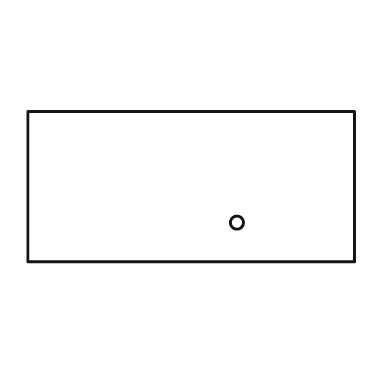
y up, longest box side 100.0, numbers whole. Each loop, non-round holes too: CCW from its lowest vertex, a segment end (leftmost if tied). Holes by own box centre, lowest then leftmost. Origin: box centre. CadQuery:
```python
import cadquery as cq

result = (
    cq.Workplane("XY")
    .moveTo(-50.0, -23.0)
    .lineTo(50.0, -23.0)
    .lineTo(50.0, 23.0)
    .lineTo(-50.0, 23.0)
    .close()
    .moveTo(14.0, -11.0)
    .circle(2.0)
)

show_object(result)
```